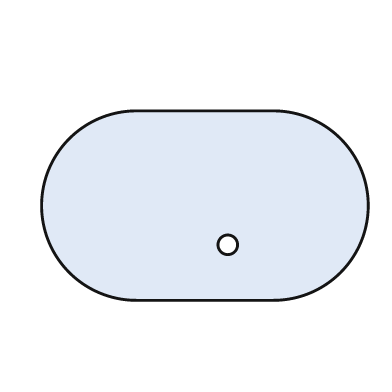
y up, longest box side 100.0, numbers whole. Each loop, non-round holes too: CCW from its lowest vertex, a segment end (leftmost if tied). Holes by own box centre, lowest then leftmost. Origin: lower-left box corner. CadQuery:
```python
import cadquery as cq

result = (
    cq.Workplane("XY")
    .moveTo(29.0, 0.0)
    .lineTo(71.0, 0.0)
    .threePointArc((100.0, 29.0), (71.0, 58.0))
    .lineTo(29.0, 58.0)
    .threePointArc((0.0, 29.0), (29.0, 0.0))
    .close()
    .moveTo(57.0, 17.0)
    .circle(3.0)
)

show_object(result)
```